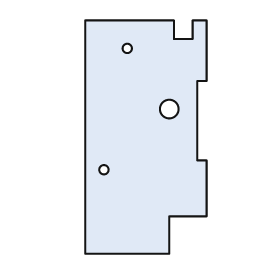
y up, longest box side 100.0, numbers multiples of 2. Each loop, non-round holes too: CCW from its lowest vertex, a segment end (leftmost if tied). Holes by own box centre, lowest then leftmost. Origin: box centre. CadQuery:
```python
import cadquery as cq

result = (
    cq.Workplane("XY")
    .moveTo(-26.0, -50.0)
    .lineTo(10.0, -50.0)
    .lineTo(10.0, -34.0)
    .lineTo(26.0, -34.0)
    .lineTo(26.0, -10.0)
    .lineTo(22.0, -10.0)
    .lineTo(22.0, 24.0)
    .lineTo(26.0, 24.0)
    .lineTo(26.0, 50.0)
    .lineTo(20.0, 50.0)
    .lineTo(20.0, 42.0)
    .lineTo(12.0, 42.0)
    .lineTo(12.0, 50.0)
    .lineTo(-26.0, 50.0)
    .close()
    .moveTo(-18.0, -14.0)
    .circle(2.0)
    .moveTo(10.0, 12.0)
    .circle(4.0)
    .moveTo(-8.0, 38.0)
    .circle(2.0)
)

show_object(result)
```